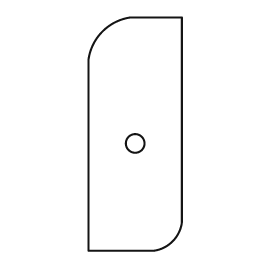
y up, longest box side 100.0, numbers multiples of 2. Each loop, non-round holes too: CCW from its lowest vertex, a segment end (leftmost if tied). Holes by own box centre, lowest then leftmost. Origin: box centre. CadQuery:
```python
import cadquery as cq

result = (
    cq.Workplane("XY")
    .moveTo(-20.0, -50.0)
    .lineTo(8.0, -50.0)
    .threePointArc((16.0, -46.0), (20.0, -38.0))
    .lineTo(20.0, 50.0)
    .lineTo(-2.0, 50.0)
    .threePointArc((-14.0, 44.0), (-20.0, 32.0))
    .close()
    .moveTo(0.0, -4.0)
    .circle(4.0)
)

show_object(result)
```